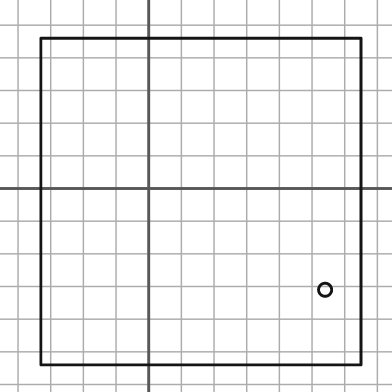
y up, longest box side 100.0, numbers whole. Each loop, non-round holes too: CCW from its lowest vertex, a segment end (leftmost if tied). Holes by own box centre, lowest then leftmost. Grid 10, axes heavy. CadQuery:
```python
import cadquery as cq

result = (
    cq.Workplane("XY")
    .moveTo(-33.0, -54.0)
    .lineTo(65.0, -54.0)
    .lineTo(65.0, 46.0)
    .lineTo(-33.0, 46.0)
    .close()
    .moveTo(54.0, -31.0)
    .circle(2.0)
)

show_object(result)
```